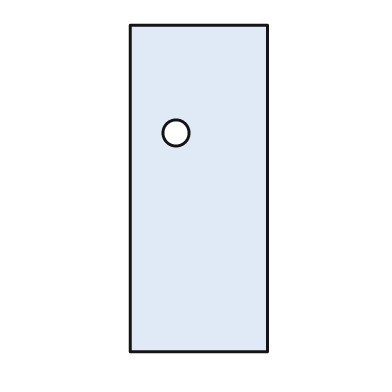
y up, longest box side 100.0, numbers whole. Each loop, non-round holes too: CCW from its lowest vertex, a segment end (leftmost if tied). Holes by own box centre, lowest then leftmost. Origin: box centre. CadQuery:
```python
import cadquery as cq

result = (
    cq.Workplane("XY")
    .moveTo(-21.0, -50.0)
    .lineTo(21.0, -50.0)
    .lineTo(21.0, 50.0)
    .lineTo(-21.0, 50.0)
    .close()
    .moveTo(-7.0, 17.0)
    .circle(4.0)
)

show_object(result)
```